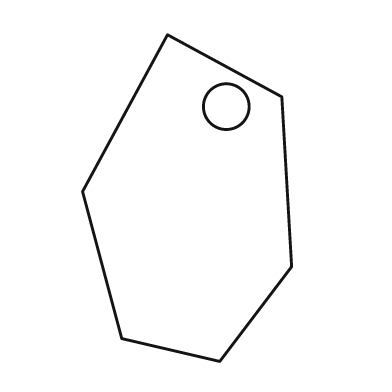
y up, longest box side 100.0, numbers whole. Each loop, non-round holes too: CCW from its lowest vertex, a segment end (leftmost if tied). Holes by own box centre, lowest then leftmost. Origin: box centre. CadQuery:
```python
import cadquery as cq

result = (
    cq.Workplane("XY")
    .moveTo(10.0, -50.0)
    .lineTo(32.0, -21.0)
    .lineTo(29.0, 31.0)
    .lineTo(-6.0, 50.0)
    .lineTo(-32.0, 2.0)
    .lineTo(-20.0, -43.0)
    .close()
    .moveTo(12.0, 28.0)
    .circle(7.0)
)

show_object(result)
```